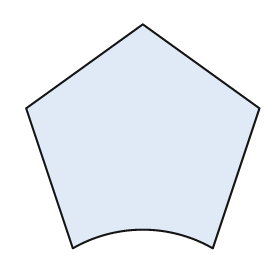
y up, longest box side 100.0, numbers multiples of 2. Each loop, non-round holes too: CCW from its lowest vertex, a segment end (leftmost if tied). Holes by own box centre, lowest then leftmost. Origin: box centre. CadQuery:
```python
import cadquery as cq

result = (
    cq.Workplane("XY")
    .moveTo(-30.0, -48.0)
    .threePointArc((0.0, -40.0), (30.0, -48.0))
    .lineTo(50.0, 12.0)
    .lineTo(0.0, 48.0)
    .lineTo(-50.0, 12.0)
    .close()
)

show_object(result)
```